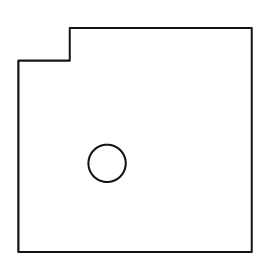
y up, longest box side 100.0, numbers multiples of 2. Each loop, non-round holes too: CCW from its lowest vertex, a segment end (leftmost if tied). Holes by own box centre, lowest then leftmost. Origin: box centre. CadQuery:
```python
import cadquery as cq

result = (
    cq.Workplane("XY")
    .moveTo(-50.0, -48.0)
    .lineTo(50.0, -48.0)
    .lineTo(50.0, 48.0)
    .lineTo(-28.0, 48.0)
    .lineTo(-28.0, 34.0)
    .lineTo(-50.0, 34.0)
    .close()
    .moveTo(-12.0, -10.0)
    .circle(8.0)
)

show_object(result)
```